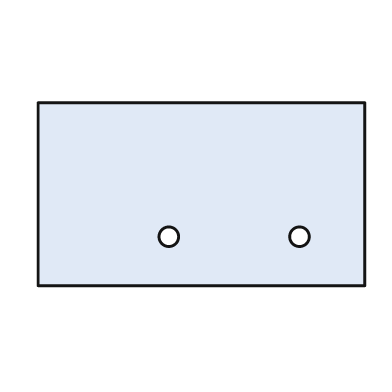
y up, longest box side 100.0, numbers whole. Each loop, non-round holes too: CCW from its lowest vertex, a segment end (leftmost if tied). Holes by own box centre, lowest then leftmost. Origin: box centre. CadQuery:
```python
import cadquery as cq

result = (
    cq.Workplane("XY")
    .moveTo(-50.0, -28.0)
    .lineTo(50.0, -28.0)
    .lineTo(50.0, 28.0)
    .lineTo(-50.0, 28.0)
    .close()
    .moveTo(-10.0, -13.0)
    .circle(3.0)
    .moveTo(30.0, -13.0)
    .circle(3.0)
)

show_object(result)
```